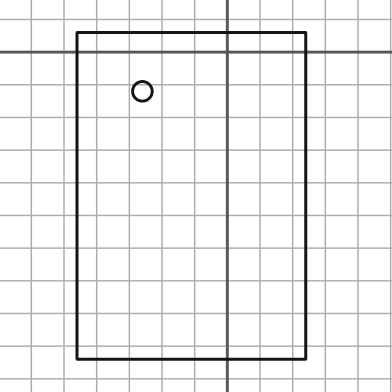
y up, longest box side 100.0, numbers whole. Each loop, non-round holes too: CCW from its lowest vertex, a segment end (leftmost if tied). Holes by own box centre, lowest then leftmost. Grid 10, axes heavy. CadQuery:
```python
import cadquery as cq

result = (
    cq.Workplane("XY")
    .moveTo(-46.0, -94.0)
    .lineTo(24.0, -94.0)
    .lineTo(24.0, 6.0)
    .lineTo(-46.0, 6.0)
    .close()
    .moveTo(-26.0, -12.0)
    .circle(3.0)
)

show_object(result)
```